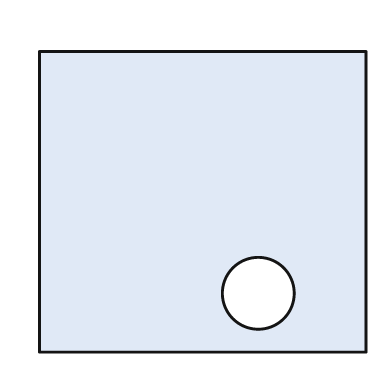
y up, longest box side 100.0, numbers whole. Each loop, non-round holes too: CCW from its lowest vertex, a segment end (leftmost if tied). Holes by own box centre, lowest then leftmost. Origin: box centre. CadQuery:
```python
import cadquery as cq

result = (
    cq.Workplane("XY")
    .moveTo(-50.0, -46.0)
    .lineTo(50.0, -46.0)
    .lineTo(50.0, 46.0)
    .lineTo(-50.0, 46.0)
    .close()
    .moveTo(17.0, -28.0)
    .circle(11.0)
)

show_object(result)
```